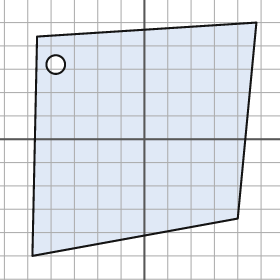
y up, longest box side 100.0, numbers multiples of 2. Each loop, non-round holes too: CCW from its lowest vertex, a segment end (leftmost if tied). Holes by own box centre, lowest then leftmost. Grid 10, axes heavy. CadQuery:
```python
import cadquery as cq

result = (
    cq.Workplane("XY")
    .moveTo(-48.0, -50.0)
    .lineTo(40.0, -34.0)
    .lineTo(48.0, 50.0)
    .lineTo(-46.0, 44.0)
    .close()
    .moveTo(-38.0, 32.0)
    .circle(4.0)
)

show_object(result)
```